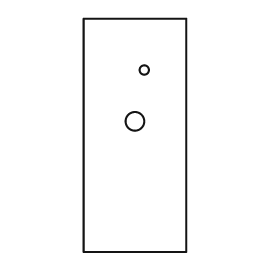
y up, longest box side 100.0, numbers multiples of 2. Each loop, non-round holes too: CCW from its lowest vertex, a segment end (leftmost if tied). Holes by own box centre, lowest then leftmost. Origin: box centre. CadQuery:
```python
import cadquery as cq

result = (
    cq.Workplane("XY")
    .moveTo(-22.0, -50.0)
    .lineTo(22.0, -50.0)
    .lineTo(22.0, 50.0)
    .lineTo(-22.0, 50.0)
    .close()
    .moveTo(0.0, 6.0)
    .circle(4.0)
    .moveTo(4.0, 28.0)
    .circle(2.0)
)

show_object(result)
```